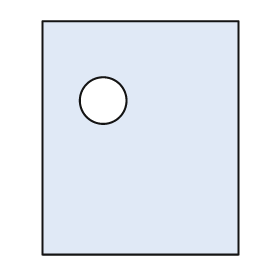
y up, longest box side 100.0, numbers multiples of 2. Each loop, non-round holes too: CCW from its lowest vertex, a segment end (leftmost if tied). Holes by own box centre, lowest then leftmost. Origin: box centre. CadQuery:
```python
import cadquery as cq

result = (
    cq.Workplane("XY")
    .moveTo(-42.0, -50.0)
    .lineTo(42.0, -50.0)
    .lineTo(42.0, 50.0)
    .lineTo(-42.0, 50.0)
    .close()
    .moveTo(-16.0, 16.0)
    .circle(10.0)
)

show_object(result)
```